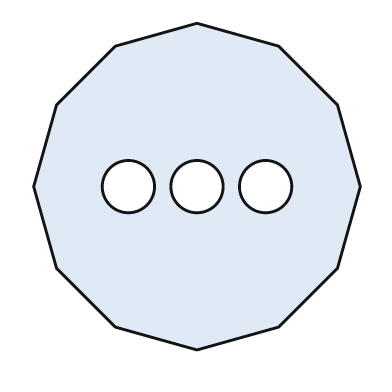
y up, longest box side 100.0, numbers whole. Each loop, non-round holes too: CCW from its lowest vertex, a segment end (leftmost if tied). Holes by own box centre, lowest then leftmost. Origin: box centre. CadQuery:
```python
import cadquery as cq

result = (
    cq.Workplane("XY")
    .moveTo(0.0, -50.0)
    .lineTo(25.0, -43.0)
    .lineTo(43.0, -25.0)
    .lineTo(50.0, 0.0)
    .lineTo(43.0, 25.0)
    .lineTo(25.0, 43.0)
    .lineTo(0.0, 50.0)
    .lineTo(-25.0, 43.0)
    .lineTo(-43.0, 25.0)
    .lineTo(-50.0, 0.0)
    .lineTo(-43.0, -25.0)
    .lineTo(-25.0, -43.0)
    .close()
    .moveTo(-21.0, 0.0)
    .circle(8.0)
    .moveTo(0.0, 0.0)
    .circle(8.0)
    .moveTo(21.0, 0.0)
    .circle(8.0)
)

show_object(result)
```